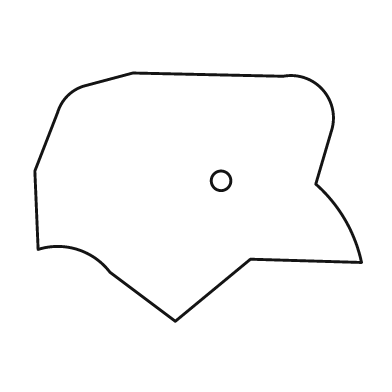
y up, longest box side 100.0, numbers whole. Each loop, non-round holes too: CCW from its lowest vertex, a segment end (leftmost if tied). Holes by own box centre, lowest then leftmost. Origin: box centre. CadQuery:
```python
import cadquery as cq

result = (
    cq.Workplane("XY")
    .moveTo(-7.0, -38.0)
    .lineTo(16.0, -19.0)
    .lineTo(50.0, -20.0)
    .threePointArc((45.0, -7.0), (36.0, 4.0))
    .lineTo(41.0, 21.0)
    .threePointArc((38.0, 33.0), (26.0, 37.0))
    .lineTo(-20.0, 38.0)
    .lineTo(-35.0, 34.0)
    .threePointArc((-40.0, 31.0), (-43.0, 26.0))
    .lineTo(-50.0, 8.0)
    .lineTo(-49.0, -16.0)
    .threePointArc((-37.0, -16.0), (-27.0, -23.0))
    .close()
    .moveTo(7.0, 5.0)
    .circle(3.0)
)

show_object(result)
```